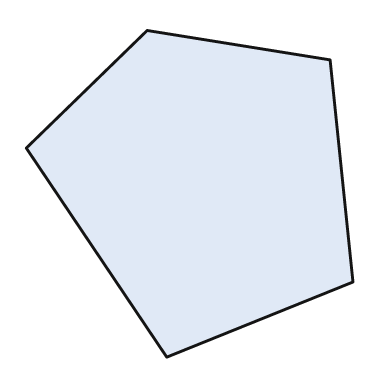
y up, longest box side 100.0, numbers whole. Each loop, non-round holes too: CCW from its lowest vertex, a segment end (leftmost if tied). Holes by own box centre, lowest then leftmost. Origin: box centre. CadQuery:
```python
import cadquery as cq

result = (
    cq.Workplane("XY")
    .moveTo(-7.0, -50.0)
    .lineTo(50.0, -27.0)
    .lineTo(43.0, 41.0)
    .lineTo(-13.0, 50.0)
    .lineTo(-50.0, 14.0)
    .close()
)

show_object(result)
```